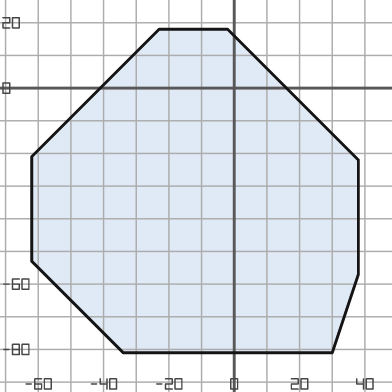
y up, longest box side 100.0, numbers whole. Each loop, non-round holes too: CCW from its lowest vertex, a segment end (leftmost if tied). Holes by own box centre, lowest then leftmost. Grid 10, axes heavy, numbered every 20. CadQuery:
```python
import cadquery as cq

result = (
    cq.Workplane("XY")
    .moveTo(-34.0, -81.0)
    .lineTo(30.0, -81.0)
    .lineTo(38.0, -57.0)
    .lineTo(38.0, -22.0)
    .lineTo(-2.0, 18.0)
    .lineTo(-23.0, 18.0)
    .lineTo(-62.0, -21.0)
    .lineTo(-62.0, -53.0)
    .close()
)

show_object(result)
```